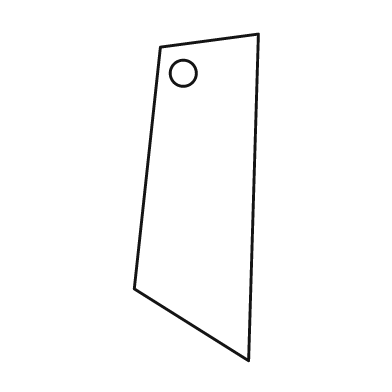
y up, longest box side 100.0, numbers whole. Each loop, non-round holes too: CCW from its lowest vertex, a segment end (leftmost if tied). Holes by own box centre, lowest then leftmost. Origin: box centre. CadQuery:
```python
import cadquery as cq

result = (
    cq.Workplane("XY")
    .moveTo(16.0, -50.0)
    .lineTo(19.0, 50.0)
    .lineTo(-11.0, 46.0)
    .lineTo(-19.0, -28.0)
    .close()
    .moveTo(-4.0, 38.0)
    .circle(4.0)
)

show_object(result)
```